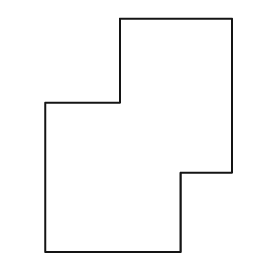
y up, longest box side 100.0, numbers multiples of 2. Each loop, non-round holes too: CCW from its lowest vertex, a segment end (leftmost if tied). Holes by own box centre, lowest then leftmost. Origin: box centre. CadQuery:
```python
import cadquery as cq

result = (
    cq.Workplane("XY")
    .moveTo(-40.0, -50.0)
    .lineTo(18.0, -50.0)
    .lineTo(18.0, -16.0)
    .lineTo(40.0, -16.0)
    .lineTo(40.0, 50.0)
    .lineTo(-8.0, 50.0)
    .lineTo(-8.0, 14.0)
    .lineTo(-40.0, 14.0)
    .close()
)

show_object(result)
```